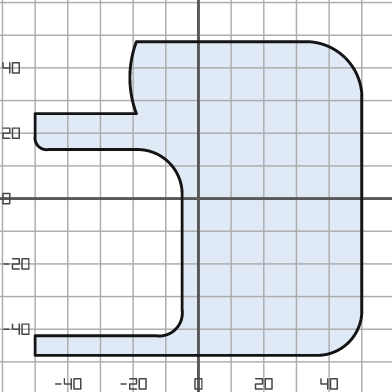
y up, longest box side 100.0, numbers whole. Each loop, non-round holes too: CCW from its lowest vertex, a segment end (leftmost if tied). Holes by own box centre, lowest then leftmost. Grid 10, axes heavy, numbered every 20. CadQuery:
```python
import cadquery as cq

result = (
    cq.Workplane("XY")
    .moveTo(-50.0, -48.0)
    .lineTo(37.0, -48.0)
    .threePointArc((46.0, -44.0), (50.0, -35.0))
    .lineTo(50.0, 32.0)
    .threePointArc((45.0, 43.0), (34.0, 48.0))
    .lineTo(-19.0, 48.0)
    .threePointArc((-21.0, 37.0), (-19.0, 26.0))
    .lineTo(-50.0, 26.0)
    .lineTo(-50.0, 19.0)
    .threePointArc((-49.0, 16.0), (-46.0, 15.0))
    .lineTo(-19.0, 15.0)
    .threePointArc((-9.0, 11.0), (-5.0, 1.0))
    .lineTo(-5.0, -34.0)
    .threePointArc((-7.0, -40.0), (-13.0, -42.0))
    .lineTo(-50.0, -42.0)
    .close()
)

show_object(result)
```